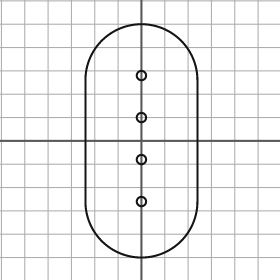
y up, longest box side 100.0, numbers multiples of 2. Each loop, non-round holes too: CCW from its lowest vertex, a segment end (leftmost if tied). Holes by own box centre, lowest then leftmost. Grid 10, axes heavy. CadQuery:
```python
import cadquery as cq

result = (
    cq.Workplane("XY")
    .moveTo(-24.0, -26.0)
    .threePointArc((0.0, -50.0), (24.0, -26.0))
    .lineTo(24.0, 26.0)
    .threePointArc((0.0, 50.0), (-24.0, 26.0))
    .close()
    .moveTo(0.0, -26.0)
    .circle(2.0)
    .moveTo(0.0, -8.0)
    .circle(2.0)
    .moveTo(0.0, 10.0)
    .circle(2.0)
    .moveTo(0.0, 28.0)
    .circle(2.0)
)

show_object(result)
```